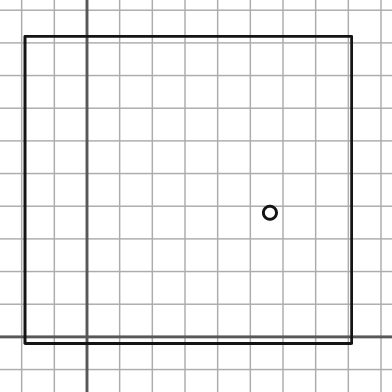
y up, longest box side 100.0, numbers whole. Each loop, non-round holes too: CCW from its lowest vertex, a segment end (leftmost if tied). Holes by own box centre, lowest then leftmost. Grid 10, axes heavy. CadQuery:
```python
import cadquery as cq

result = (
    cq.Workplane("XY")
    .moveTo(-19.0, -2.0)
    .lineTo(81.0, -2.0)
    .lineTo(81.0, 92.0)
    .lineTo(-19.0, 92.0)
    .close()
    .moveTo(56.0, 38.0)
    .circle(2.0)
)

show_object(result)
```